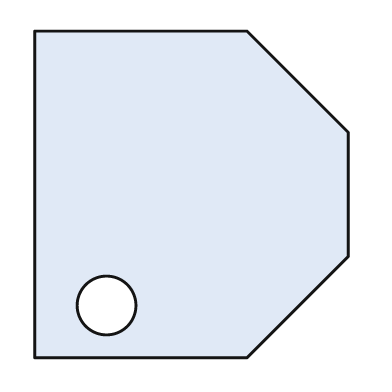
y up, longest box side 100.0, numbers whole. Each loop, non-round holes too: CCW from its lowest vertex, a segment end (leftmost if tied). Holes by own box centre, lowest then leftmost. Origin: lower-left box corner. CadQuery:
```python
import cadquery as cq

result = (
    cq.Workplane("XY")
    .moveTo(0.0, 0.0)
    .lineTo(65.0, 0.0)
    .lineTo(96.0, 31.0)
    .lineTo(96.0, 69.0)
    .lineTo(65.0, 100.0)
    .lineTo(0.0, 100.0)
    .close()
    .moveTo(22.0, 16.0)
    .circle(9.0)
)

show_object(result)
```